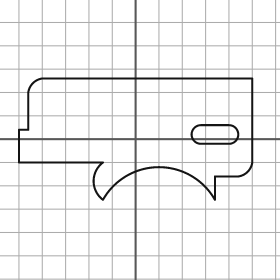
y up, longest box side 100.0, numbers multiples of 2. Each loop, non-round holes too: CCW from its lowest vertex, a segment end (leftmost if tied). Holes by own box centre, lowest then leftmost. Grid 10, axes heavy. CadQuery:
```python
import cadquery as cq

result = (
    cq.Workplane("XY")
    .moveTo(-14.0, -26.0)
    .threePointArc((10.0, -12.0), (34.0, -26.0))
    .lineTo(34.0, -16.0)
    .lineTo(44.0, -16.0)
    .threePointArc((48.0, -14.0), (50.0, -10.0))
    .lineTo(50.0, 26.0)
    .lineTo(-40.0, 26.0)
    .threePointArc((-44.0, 24.0), (-46.0, 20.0))
    .lineTo(-46.0, 4.0)
    .lineTo(-50.0, 4.0)
    .lineTo(-50.0, -10.0)
    .lineTo(-14.0, -10.0)
    .threePointArc((-18.0, -18.0), (-14.0, -26.0))
    .close()
    .moveTo(28.0, -2.0)
    .lineTo(40.0, -2.0)
    .threePointArc((44.0, 2.0), (40.0, 6.0))
    .lineTo(28.0, 6.0)
    .threePointArc((24.0, 2.0), (28.0, -2.0))
    .close()
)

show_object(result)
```